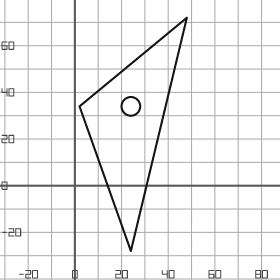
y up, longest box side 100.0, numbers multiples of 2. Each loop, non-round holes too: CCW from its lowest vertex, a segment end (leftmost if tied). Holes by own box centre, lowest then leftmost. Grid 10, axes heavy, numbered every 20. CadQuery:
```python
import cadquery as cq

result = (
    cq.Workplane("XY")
    .moveTo(24.0, -28.0)
    .lineTo(48.0, 72.0)
    .lineTo(2.0, 34.0)
    .close()
    .moveTo(24.0, 34.0)
    .circle(4.0)
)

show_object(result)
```